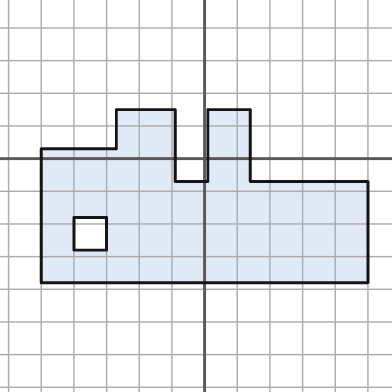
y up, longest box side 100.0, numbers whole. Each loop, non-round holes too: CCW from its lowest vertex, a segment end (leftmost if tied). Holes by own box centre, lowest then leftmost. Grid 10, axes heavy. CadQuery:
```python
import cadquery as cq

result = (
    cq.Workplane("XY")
    .moveTo(-50.0, -38.0)
    .lineTo(50.0, -38.0)
    .lineTo(50.0, -7.0)
    .lineTo(14.0, -7.0)
    .lineTo(14.0, 15.0)
    .lineTo(1.0, 15.0)
    .lineTo(1.0, -7.0)
    .lineTo(-9.0, -7.0)
    .lineTo(-9.0, 15.0)
    .lineTo(-27.0, 15.0)
    .lineTo(-27.0, 3.0)
    .lineTo(-50.0, 3.0)
    .close()
    .moveTo(-40.0, -28.0)
    .lineTo(-30.0, -28.0)
    .lineTo(-30.0, -18.0)
    .lineTo(-40.0, -18.0)
    .close()
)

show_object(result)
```